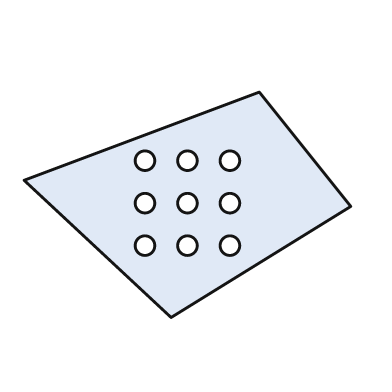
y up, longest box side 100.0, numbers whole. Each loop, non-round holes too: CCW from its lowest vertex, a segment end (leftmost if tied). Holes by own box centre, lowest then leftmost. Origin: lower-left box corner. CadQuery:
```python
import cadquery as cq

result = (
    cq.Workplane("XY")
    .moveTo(45.0, 0.0)
    .lineTo(100.0, 34.0)
    .lineTo(72.0, 69.0)
    .lineTo(0.0, 42.0)
    .close()
    .moveTo(37.0, 22.0)
    .circle(3.0)
    .moveTo(50.0, 22.0)
    .circle(3.0)
    .moveTo(63.0, 22.0)
    .circle(3.0)
    .moveTo(37.0, 35.0)
    .circle(3.0)
    .moveTo(50.0, 35.0)
    .circle(3.0)
    .moveTo(63.0, 35.0)
    .circle(3.0)
    .moveTo(37.0, 48.0)
    .circle(3.0)
    .moveTo(50.0, 48.0)
    .circle(3.0)
    .moveTo(63.0, 48.0)
    .circle(3.0)
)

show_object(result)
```